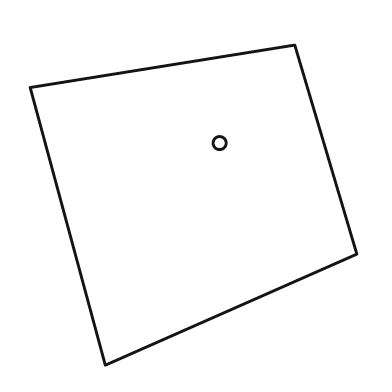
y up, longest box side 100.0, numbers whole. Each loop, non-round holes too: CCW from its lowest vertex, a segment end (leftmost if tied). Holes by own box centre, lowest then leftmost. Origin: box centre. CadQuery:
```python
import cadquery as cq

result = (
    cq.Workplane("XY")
    .moveTo(-27.0, -49.0)
    .lineTo(50.0, -15.0)
    .lineTo(31.0, 49.0)
    .lineTo(-50.0, 36.0)
    .close()
    .moveTo(8.0, 19.0)
    .circle(2.0)
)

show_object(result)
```